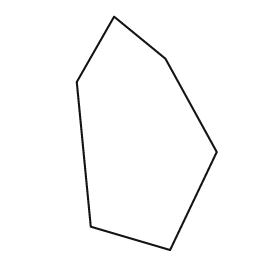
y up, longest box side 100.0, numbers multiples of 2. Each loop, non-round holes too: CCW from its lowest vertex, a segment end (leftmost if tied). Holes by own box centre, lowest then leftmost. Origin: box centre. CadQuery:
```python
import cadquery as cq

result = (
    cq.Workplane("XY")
    .moveTo(10.0, -50.0)
    .lineTo(30.0, -8.0)
    .lineTo(8.0, 32.0)
    .lineTo(-14.0, 50.0)
    .lineTo(-30.0, 22.0)
    .lineTo(-24.0, -40.0)
    .close()
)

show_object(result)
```